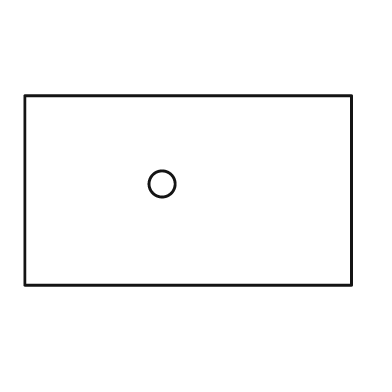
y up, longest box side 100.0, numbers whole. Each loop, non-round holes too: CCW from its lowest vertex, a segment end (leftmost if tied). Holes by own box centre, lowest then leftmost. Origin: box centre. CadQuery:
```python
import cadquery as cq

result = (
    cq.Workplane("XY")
    .moveTo(-50.0, -29.0)
    .lineTo(50.0, -29.0)
    .lineTo(50.0, 29.0)
    .lineTo(-50.0, 29.0)
    .close()
    .moveTo(-8.0, 2.0)
    .circle(4.0)
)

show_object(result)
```